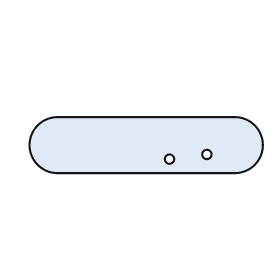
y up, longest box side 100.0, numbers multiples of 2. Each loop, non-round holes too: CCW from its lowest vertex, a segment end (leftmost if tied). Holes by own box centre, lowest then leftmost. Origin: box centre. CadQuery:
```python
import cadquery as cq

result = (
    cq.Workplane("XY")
    .moveTo(-38.0, -12.0)
    .lineTo(38.0, -12.0)
    .threePointArc((50.0, 0.0), (38.0, 12.0))
    .lineTo(-38.0, 12.0)
    .threePointArc((-50.0, 0.0), (-38.0, -12.0))
    .close()
    .moveTo(10.0, -6.0)
    .circle(2.0)
    .moveTo(26.0, -4.0)
    .circle(2.0)
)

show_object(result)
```